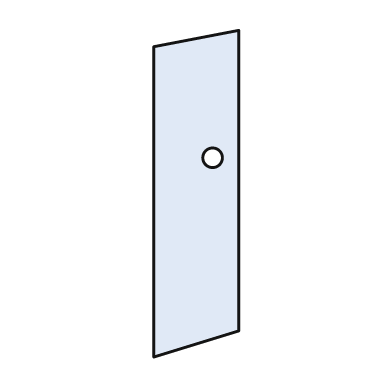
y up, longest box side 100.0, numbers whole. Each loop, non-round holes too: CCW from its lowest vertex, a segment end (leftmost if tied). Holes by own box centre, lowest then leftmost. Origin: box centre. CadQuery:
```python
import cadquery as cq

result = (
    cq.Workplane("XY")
    .moveTo(-13.0, -50.0)
    .lineTo(13.0, -42.0)
    .lineTo(13.0, 50.0)
    .lineTo(-13.0, 45.0)
    .close()
    .moveTo(5.0, 11.0)
    .circle(3.0)
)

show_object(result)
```